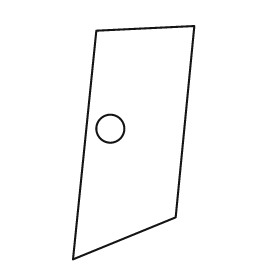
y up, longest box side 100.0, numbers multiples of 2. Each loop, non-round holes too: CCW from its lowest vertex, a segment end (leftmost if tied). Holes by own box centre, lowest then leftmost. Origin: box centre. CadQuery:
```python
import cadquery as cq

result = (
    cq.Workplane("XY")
    .moveTo(-26.0, -50.0)
    .lineTo(18.0, -32.0)
    .lineTo(26.0, 50.0)
    .lineTo(-16.0, 48.0)
    .close()
    .moveTo(-10.0, 6.0)
    .circle(6.0)
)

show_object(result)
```